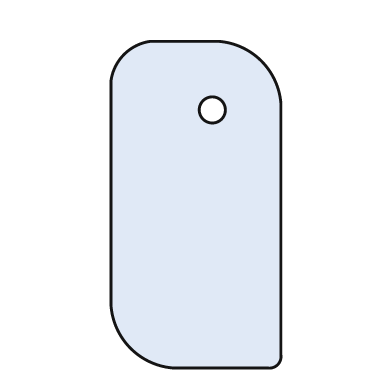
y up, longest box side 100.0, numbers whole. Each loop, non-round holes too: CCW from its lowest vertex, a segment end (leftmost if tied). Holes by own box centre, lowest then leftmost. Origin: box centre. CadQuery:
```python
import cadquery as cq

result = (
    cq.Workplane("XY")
    .moveTo(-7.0, -50.0)
    .lineTo(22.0, -50.0)
    .threePointArc((25.0, -49.0), (26.0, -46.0))
    .lineTo(26.0, 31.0)
    .threePointArc((20.0, 44.0), (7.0, 50.0))
    .lineTo(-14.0, 50.0)
    .threePointArc((-22.0, 46.0), (-26.0, 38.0))
    .lineTo(-26.0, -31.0)
    .threePointArc((-20.0, -44.0), (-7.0, -50.0))
    .close()
    .moveTo(5.0, 29.0)
    .circle(4.0)
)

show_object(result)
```